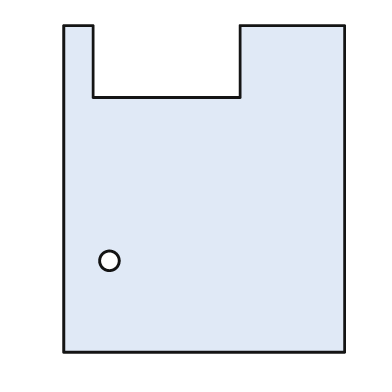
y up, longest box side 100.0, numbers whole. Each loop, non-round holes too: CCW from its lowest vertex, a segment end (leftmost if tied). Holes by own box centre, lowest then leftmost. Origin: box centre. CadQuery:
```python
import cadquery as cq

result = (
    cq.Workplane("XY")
    .moveTo(-43.0, -50.0)
    .lineTo(43.0, -50.0)
    .lineTo(43.0, 50.0)
    .lineTo(11.0, 50.0)
    .lineTo(11.0, 28.0)
    .lineTo(-34.0, 28.0)
    .lineTo(-34.0, 50.0)
    .lineTo(-43.0, 50.0)
    .close()
    .moveTo(-29.0, -22.0)
    .circle(3.0)
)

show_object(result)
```